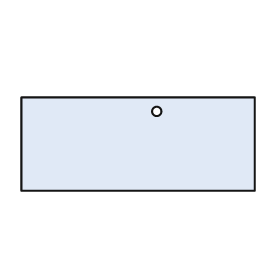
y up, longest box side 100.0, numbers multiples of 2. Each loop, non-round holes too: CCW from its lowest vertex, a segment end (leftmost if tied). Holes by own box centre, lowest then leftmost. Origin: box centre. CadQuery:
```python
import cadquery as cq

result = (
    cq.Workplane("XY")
    .moveTo(-50.0, -20.0)
    .lineTo(50.0, -20.0)
    .lineTo(50.0, 20.0)
    .lineTo(-50.0, 20.0)
    .close()
    .moveTo(8.0, 14.0)
    .circle(2.0)
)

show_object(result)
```